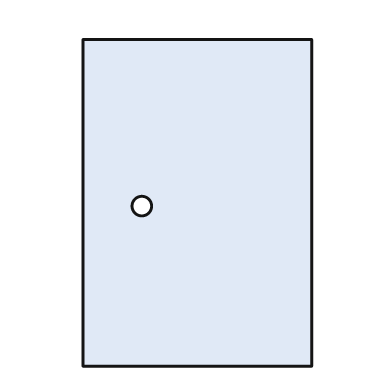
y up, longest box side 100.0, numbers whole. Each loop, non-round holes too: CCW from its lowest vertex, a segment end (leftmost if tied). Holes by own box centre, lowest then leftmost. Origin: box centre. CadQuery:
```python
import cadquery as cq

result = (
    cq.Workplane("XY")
    .moveTo(-35.0, -50.0)
    .lineTo(35.0, -50.0)
    .lineTo(35.0, 50.0)
    .lineTo(-35.0, 50.0)
    .close()
    .moveTo(-17.0, -1.0)
    .circle(3.0)
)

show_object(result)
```